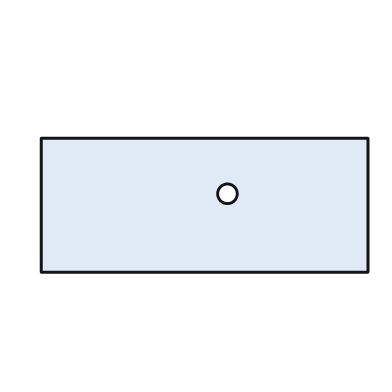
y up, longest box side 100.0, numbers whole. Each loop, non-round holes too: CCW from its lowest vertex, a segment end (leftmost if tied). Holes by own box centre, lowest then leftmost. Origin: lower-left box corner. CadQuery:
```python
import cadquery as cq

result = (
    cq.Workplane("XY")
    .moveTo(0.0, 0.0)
    .lineTo(100.0, 0.0)
    .lineTo(100.0, 41.0)
    .lineTo(0.0, 41.0)
    .close()
    .moveTo(57.0, 24.0)
    .circle(3.0)
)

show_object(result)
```